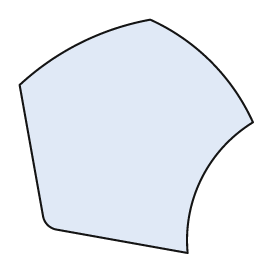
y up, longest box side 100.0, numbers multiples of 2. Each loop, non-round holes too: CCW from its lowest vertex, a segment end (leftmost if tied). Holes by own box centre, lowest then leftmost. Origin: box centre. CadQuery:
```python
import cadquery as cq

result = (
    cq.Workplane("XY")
    .moveTo(22.0, -50.0)
    .threePointArc((28.0, -18.0), (50.0, 6.0))
    .threePointArc((32.0, 32.0), (6.0, 50.0))
    .threePointArc((-24.0, 40.0), (-50.0, 22.0))
    .lineTo(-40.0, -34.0)
    .threePointArc((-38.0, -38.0), (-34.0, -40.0))
    .close()
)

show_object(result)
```